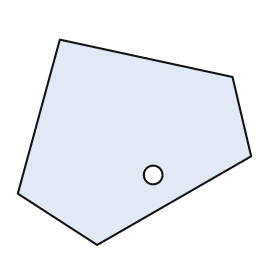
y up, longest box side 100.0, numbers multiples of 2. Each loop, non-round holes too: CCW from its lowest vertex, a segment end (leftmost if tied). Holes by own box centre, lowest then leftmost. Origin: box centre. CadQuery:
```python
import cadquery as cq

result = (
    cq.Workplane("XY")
    .moveTo(-16.0, -44.0)
    .lineTo(50.0, -6.0)
    .lineTo(42.0, 28.0)
    .lineTo(-32.0, 44.0)
    .lineTo(-50.0, -22.0)
    .close()
    .moveTo(8.0, -14.0)
    .circle(4.0)
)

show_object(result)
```